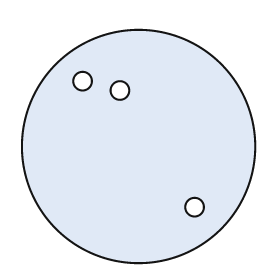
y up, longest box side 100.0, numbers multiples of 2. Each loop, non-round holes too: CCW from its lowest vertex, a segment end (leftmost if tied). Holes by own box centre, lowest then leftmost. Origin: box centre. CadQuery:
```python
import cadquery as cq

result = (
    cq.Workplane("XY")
    .moveTo(0.0, 0.0)
    .circle(50.0)
    .moveTo(24.0, -26.0)
    .circle(4.0)
    .moveTo(-8.0, 24.0)
    .circle(4.0)
    .moveTo(-24.0, 28.0)
    .circle(4.0)
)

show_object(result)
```